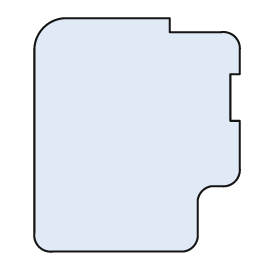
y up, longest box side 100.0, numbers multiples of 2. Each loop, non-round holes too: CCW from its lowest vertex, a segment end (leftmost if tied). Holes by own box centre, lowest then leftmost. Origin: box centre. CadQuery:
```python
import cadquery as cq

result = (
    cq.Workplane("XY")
    .moveTo(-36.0, -50.0)
    .lineTo(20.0, -50.0)
    .threePointArc((24.0, -48.0), (26.0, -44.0))
    .lineTo(26.0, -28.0)
    .threePointArc((28.0, -24.0), (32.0, -22.0))
    .lineTo(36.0, -22.0)
    .threePointArc((42.0, -20.0), (44.0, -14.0))
    .lineTo(44.0, 6.0)
    .lineTo(40.0, 6.0)
    .lineTo(40.0, 26.0)
    .lineTo(44.0, 26.0)
    .lineTo(44.0, 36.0)
    .threePointArc((42.0, 42.0), (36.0, 44.0))
    .lineTo(14.0, 44.0)
    .lineTo(14.0, 50.0)
    .lineTo(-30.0, 50.0)
    .threePointArc((-40.0, 46.0), (-44.0, 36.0))
    .lineTo(-44.0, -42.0)
    .threePointArc((-42.0, -48.0), (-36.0, -50.0))
    .close()
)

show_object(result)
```